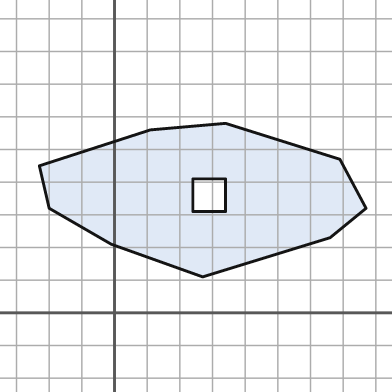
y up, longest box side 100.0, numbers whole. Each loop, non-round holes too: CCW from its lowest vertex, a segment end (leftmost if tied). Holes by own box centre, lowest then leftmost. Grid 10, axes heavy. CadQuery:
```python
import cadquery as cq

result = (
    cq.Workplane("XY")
    .moveTo(27.0, 11.0)
    .lineTo(66.0, 23.0)
    .lineTo(77.0, 32.0)
    .lineTo(69.0, 47.0)
    .lineTo(34.0, 58.0)
    .lineTo(11.0, 56.0)
    .lineTo(-23.0, 45.0)
    .lineTo(-20.0, 32.0)
    .lineTo(-1.0, 21.0)
    .close()
    .moveTo(24.0, 31.0)
    .lineTo(34.0, 31.0)
    .lineTo(34.0, 41.0)
    .lineTo(24.0, 41.0)
    .close()
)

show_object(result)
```